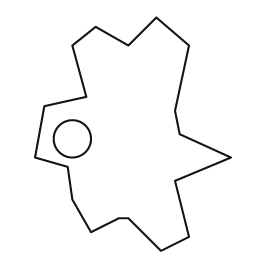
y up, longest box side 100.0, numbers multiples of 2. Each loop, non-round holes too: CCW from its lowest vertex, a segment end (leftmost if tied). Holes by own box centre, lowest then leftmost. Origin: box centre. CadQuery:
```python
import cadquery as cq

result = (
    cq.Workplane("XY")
    .moveTo(12.0, -50.0)
    .lineTo(24.0, -44.0)
    .lineTo(18.0, -20.0)
    .lineTo(42.0, -10.0)
    .lineTo(20.0, 0.0)
    .lineTo(18.0, 10.0)
    .lineTo(24.0, 38.0)
    .lineTo(10.0, 50.0)
    .lineTo(-2.0, 38.0)
    .lineTo(-16.0, 46.0)
    .lineTo(-26.0, 38.0)
    .lineTo(-20.0, 16.0)
    .lineTo(-38.0, 12.0)
    .lineTo(-42.0, -10.0)
    .lineTo(-28.0, -14.0)
    .lineTo(-26.0, -28.0)
    .lineTo(-18.0, -42.0)
    .lineTo(-6.0, -36.0)
    .lineTo(-2.0, -36.0)
    .close()
    .moveTo(-26.0, -2.0)
    .circle(8.0)
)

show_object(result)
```